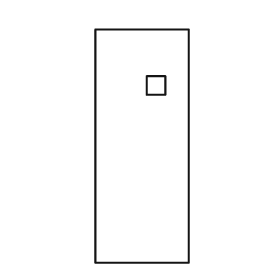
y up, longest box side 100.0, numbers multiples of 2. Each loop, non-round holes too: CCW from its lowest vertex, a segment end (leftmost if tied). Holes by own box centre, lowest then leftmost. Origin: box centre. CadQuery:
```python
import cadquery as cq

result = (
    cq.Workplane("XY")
    .moveTo(-20.0, -50.0)
    .lineTo(20.0, -50.0)
    .lineTo(20.0, 50.0)
    .lineTo(-20.0, 50.0)
    .close()
    .moveTo(2.0, 22.0)
    .lineTo(10.0, 22.0)
    .lineTo(10.0, 30.0)
    .lineTo(2.0, 30.0)
    .close()
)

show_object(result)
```